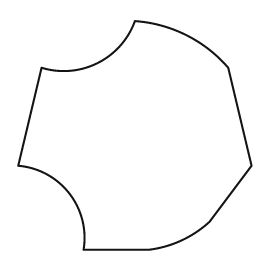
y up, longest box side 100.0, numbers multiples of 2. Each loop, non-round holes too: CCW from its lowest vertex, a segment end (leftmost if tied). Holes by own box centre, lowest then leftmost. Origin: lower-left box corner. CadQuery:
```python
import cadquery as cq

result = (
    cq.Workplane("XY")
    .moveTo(28.0, 0.0)
    .lineTo(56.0, 0.0)
    .threePointArc((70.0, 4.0), (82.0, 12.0))
    .lineTo(100.0, 36.0)
    .lineTo(90.0, 78.0)
    .threePointArc((72.0, 92.0), (50.0, 98.0))
    .threePointArc((34.0, 80.0), (10.0, 78.0))
    .lineTo(0.0, 36.0)
    .threePointArc((22.0, 24.0), (28.0, 0.0))
    .close()
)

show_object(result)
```